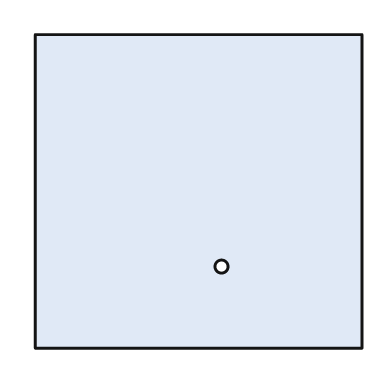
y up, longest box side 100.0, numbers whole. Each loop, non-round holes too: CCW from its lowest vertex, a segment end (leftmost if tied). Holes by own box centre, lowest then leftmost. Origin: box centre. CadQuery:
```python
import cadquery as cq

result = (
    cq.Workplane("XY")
    .moveTo(-50.0, -48.0)
    .lineTo(50.0, -48.0)
    .lineTo(50.0, 48.0)
    .lineTo(-50.0, 48.0)
    .close()
    .moveTo(7.0, -23.0)
    .circle(2.0)
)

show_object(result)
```